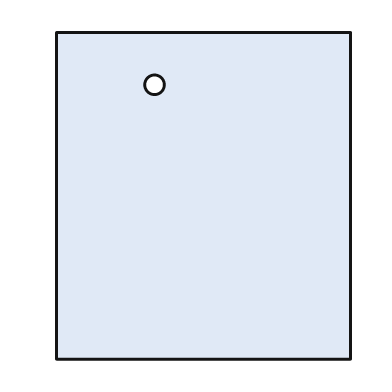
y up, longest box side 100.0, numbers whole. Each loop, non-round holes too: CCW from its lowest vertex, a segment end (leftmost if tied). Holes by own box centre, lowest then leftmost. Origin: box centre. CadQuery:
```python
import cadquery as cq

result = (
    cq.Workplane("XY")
    .moveTo(-45.0, -50.0)
    .lineTo(45.0, -50.0)
    .lineTo(45.0, 50.0)
    .lineTo(-45.0, 50.0)
    .close()
    .moveTo(-15.0, 34.0)
    .circle(3.0)
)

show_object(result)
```